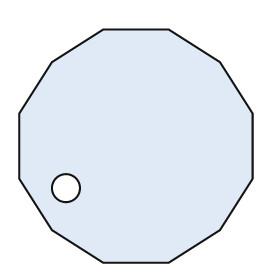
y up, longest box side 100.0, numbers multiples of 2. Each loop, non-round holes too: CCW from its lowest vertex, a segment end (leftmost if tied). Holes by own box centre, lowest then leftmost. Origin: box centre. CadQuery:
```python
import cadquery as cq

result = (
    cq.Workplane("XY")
    .moveTo(-14.0, -50.0)
    .lineTo(14.0, -50.0)
    .lineTo(36.0, -36.0)
    .lineTo(50.0, -14.0)
    .lineTo(50.0, 14.0)
    .lineTo(36.0, 36.0)
    .lineTo(14.0, 50.0)
    .lineTo(-14.0, 50.0)
    .lineTo(-36.0, 36.0)
    .lineTo(-50.0, 14.0)
    .lineTo(-50.0, -14.0)
    .lineTo(-36.0, -36.0)
    .close()
    .moveTo(-30.0, -18.0)
    .circle(6.0)
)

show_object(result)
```